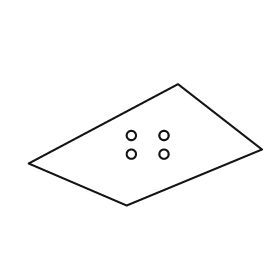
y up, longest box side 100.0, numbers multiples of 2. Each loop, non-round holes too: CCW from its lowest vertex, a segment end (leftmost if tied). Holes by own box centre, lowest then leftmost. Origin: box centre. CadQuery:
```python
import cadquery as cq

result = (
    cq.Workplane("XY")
    .moveTo(-8.0, -26.0)
    .lineTo(50.0, -2.0)
    .lineTo(14.0, 26.0)
    .lineTo(-50.0, -8.0)
    .close()
    .moveTo(-6.0, -4.0)
    .circle(2.0)
    .moveTo(8.0, -4.0)
    .circle(2.0)
    .moveTo(-6.0, 4.0)
    .circle(2.0)
    .moveTo(8.0, 4.0)
    .circle(2.0)
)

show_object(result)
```